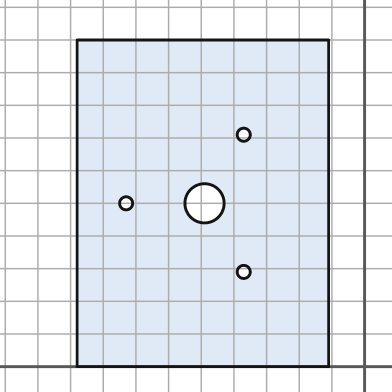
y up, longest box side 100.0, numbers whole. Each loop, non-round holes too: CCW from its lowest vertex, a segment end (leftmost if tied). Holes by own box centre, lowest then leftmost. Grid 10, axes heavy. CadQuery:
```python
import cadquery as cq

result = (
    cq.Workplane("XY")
    .moveTo(-88.0, 0.0)
    .lineTo(-11.0, 0.0)
    .lineTo(-11.0, 100.0)
    .lineTo(-88.0, 100.0)
    .close()
    .moveTo(-37.0, 29.0)
    .circle(2.0)
    .moveTo(-73.0, 50.0)
    .circle(2.0)
    .moveTo(-49.0, 50.0)
    .circle(6.0)
    .moveTo(-37.0, 71.0)
    .circle(2.0)
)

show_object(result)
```